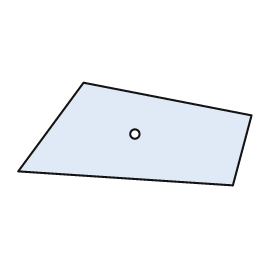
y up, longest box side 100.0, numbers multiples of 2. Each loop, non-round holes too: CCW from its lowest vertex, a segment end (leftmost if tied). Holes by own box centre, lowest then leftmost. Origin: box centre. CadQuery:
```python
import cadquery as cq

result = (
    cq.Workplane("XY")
    .moveTo(42.0, -22.0)
    .lineTo(50.0, 8.0)
    .lineTo(-22.0, 22.0)
    .lineTo(-50.0, -16.0)
    .close()
    .moveTo(0.0, 0.0)
    .circle(2.0)
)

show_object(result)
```